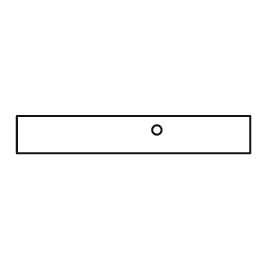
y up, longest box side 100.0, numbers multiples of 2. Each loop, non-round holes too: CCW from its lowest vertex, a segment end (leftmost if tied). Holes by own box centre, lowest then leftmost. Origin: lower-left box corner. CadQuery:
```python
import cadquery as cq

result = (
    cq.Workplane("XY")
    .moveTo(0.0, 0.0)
    .lineTo(100.0, 0.0)
    .lineTo(100.0, 16.0)
    .lineTo(0.0, 16.0)
    .close()
    .moveTo(60.0, 10.0)
    .circle(2.0)
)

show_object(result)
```